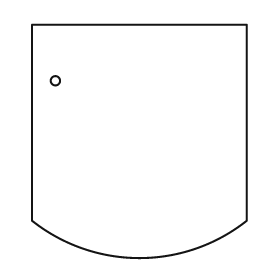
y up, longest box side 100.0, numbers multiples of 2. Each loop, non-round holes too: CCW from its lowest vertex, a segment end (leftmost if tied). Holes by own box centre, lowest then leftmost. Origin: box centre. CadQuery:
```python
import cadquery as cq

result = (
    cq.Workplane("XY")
    .moveTo(-46.0, -34.0)
    .threePointArc((0.0, -50.0), (46.0, -34.0))
    .lineTo(46.0, 50.0)
    .lineTo(-46.0, 50.0)
    .close()
    .moveTo(-36.0, 26.0)
    .circle(2.0)
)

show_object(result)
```